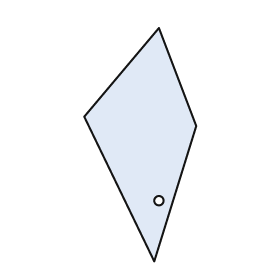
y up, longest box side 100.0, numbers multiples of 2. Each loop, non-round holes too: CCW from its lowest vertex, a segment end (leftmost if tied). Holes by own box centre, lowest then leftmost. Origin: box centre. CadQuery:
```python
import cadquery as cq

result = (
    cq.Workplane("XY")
    .moveTo(6.0, -50.0)
    .lineTo(24.0, 8.0)
    .lineTo(8.0, 50.0)
    .lineTo(-24.0, 12.0)
    .close()
    .moveTo(8.0, -24.0)
    .circle(2.0)
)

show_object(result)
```